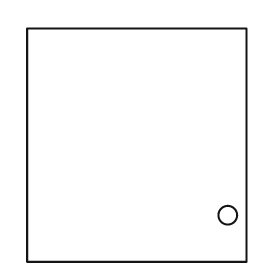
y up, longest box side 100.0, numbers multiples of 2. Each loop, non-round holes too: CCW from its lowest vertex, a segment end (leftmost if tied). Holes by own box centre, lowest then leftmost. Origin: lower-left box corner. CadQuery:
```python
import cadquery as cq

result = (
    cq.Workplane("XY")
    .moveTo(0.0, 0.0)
    .lineTo(94.0, 0.0)
    .lineTo(94.0, 100.0)
    .lineTo(0.0, 100.0)
    .close()
    .moveTo(86.0, 20.0)
    .circle(4.0)
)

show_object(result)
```